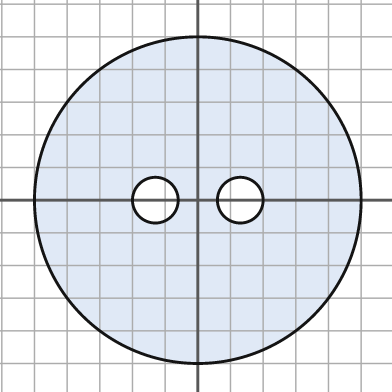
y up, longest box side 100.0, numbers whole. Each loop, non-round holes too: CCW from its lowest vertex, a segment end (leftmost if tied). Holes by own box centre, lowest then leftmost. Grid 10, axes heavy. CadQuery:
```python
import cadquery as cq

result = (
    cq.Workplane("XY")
    .moveTo(0.0, 0.0)
    .circle(50.0)
    .moveTo(-13.0, 0.0)
    .circle(7.0)
    .moveTo(13.0, 0.0)
    .circle(7.0)
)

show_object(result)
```